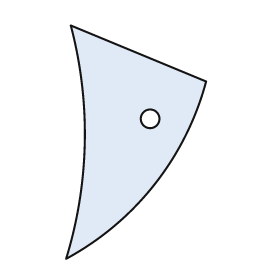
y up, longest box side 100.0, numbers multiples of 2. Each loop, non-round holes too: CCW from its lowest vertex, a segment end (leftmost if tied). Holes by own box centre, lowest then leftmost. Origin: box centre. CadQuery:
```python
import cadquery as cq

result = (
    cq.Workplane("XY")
    .moveTo(-30.0, -50.0)
    .threePointArc((8.0, -18.0), (30.0, 26.0))
    .lineTo(-28.0, 50.0)
    .threePointArc((-22.0, 0.0), (-30.0, -50.0))
    .close()
    .moveTo(6.0, 10.0)
    .circle(4.0)
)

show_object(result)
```